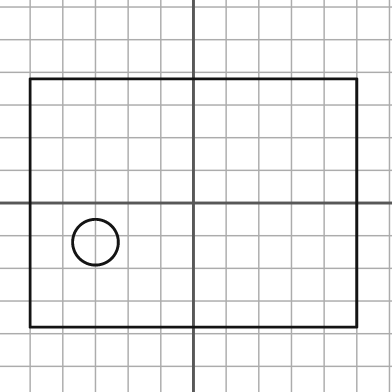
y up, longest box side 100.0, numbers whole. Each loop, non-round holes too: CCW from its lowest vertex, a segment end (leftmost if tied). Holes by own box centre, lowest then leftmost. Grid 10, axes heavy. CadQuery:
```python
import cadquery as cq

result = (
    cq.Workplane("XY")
    .moveTo(-50.0, -38.0)
    .lineTo(50.0, -38.0)
    .lineTo(50.0, 38.0)
    .lineTo(-50.0, 38.0)
    .close()
    .moveTo(-30.0, -12.0)
    .circle(7.0)
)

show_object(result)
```